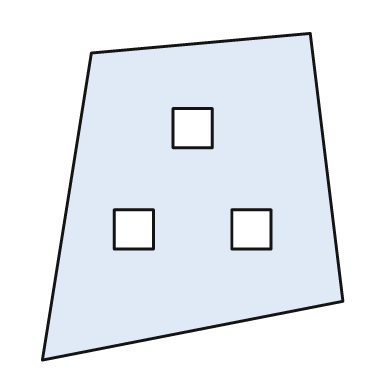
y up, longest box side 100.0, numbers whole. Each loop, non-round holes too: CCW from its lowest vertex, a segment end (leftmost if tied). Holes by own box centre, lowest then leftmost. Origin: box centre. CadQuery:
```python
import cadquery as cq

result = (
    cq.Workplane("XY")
    .moveTo(-46.0, -50.0)
    .lineTo(46.0, -32.0)
    .lineTo(36.0, 50.0)
    .lineTo(-31.0, 44.0)
    .close()
    .moveTo(-24.0, -16.0)
    .lineTo(-12.0, -16.0)
    .lineTo(-12.0, -4.0)
    .lineTo(-24.0, -4.0)
    .close()
    .moveTo(12.0, -16.0)
    .lineTo(24.0, -16.0)
    .lineTo(24.0, -4.0)
    .lineTo(12.0, -4.0)
    .close()
    .moveTo(-6.0, 15.0)
    .lineTo(6.0, 15.0)
    .lineTo(6.0, 27.0)
    .lineTo(-6.0, 27.0)
    .close()
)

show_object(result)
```